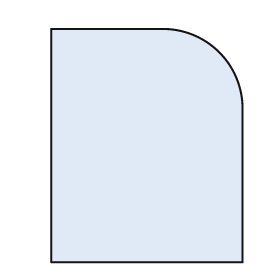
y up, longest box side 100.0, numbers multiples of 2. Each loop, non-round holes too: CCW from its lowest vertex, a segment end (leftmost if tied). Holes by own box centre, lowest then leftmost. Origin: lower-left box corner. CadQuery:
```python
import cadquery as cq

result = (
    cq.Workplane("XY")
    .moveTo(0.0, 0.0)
    .lineTo(82.0, 0.0)
    .lineTo(82.0, 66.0)
    .threePointArc((72.0, 90.0), (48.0, 100.0))
    .lineTo(0.0, 100.0)
    .close()
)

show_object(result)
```